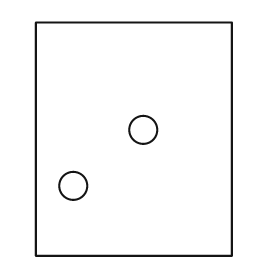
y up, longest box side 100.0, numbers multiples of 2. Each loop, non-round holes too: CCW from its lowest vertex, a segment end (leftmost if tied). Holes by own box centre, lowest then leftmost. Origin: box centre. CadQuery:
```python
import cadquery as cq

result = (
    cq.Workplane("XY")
    .moveTo(-42.0, -50.0)
    .lineTo(42.0, -50.0)
    .lineTo(42.0, 50.0)
    .lineTo(-42.0, 50.0)
    .close()
    .moveTo(-26.0, -20.0)
    .circle(6.0)
    .moveTo(4.0, 4.0)
    .circle(6.0)
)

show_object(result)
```